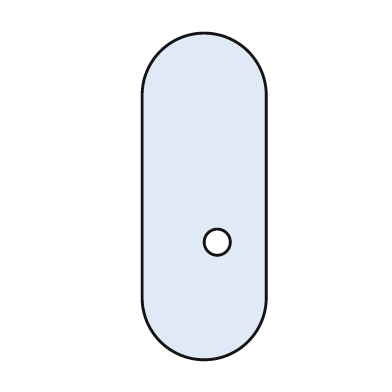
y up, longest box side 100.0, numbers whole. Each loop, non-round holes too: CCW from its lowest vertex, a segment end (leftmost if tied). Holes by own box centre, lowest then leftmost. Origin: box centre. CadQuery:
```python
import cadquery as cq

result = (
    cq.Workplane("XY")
    .moveTo(-19.0, -31.0)
    .threePointArc((0.0, -50.0), (19.0, -31.0))
    .lineTo(19.0, 31.0)
    .threePointArc((0.0, 50.0), (-19.0, 31.0))
    .close()
    .moveTo(4.0, -14.0)
    .circle(4.0)
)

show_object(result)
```